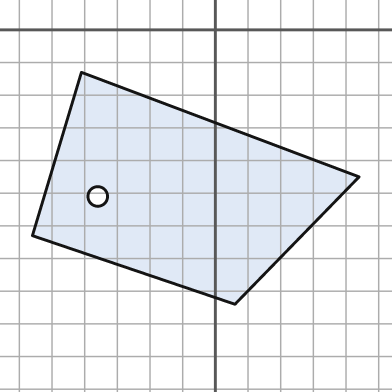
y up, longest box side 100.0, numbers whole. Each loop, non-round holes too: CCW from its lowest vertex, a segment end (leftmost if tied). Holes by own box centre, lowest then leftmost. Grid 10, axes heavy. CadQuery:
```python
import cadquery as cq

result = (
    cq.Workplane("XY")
    .moveTo(6.0, -84.0)
    .lineTo(44.0, -45.0)
    .lineTo(-41.0, -13.0)
    .lineTo(-56.0, -63.0)
    .close()
    .moveTo(-36.0, -51.0)
    .circle(3.0)
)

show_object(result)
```